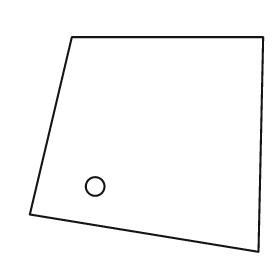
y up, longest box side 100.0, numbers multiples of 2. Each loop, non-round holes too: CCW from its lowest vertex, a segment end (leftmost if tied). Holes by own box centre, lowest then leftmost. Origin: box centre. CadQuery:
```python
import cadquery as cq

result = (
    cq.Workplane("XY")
    .moveTo(48.0, -46.0)
    .lineTo(50.0, 46.0)
    .lineTo(-32.0, 46.0)
    .lineTo(-50.0, -30.0)
    .close()
    .moveTo(-22.0, -18.0)
    .circle(4.0)
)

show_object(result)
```